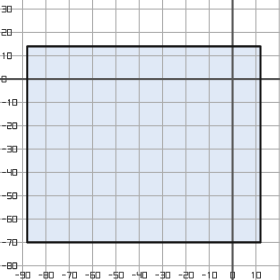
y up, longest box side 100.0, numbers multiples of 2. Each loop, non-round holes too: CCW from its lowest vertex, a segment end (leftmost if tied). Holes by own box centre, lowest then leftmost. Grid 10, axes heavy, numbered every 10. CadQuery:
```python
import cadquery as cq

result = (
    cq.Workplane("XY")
    .moveTo(-88.0, -70.0)
    .lineTo(12.0, -70.0)
    .lineTo(12.0, 14.0)
    .lineTo(-88.0, 14.0)
    .close()
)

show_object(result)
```